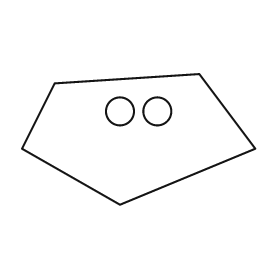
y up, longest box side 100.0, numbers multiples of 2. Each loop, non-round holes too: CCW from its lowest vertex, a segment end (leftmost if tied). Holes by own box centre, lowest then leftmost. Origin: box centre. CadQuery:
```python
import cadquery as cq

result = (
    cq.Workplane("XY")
    .moveTo(-8.0, -28.0)
    .lineTo(50.0, -4.0)
    .lineTo(26.0, 28.0)
    .lineTo(-36.0, 24.0)
    .lineTo(-50.0, -4.0)
    .close()
    .moveTo(-8.0, 12.0)
    .circle(6.0)
    .moveTo(8.0, 12.0)
    .circle(6.0)
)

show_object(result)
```